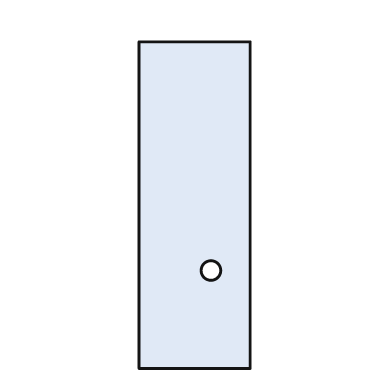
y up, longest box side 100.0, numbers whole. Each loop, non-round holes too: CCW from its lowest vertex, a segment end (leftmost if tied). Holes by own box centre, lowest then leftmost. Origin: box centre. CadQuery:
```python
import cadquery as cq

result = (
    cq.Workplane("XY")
    .moveTo(-17.0, -50.0)
    .lineTo(17.0, -50.0)
    .lineTo(17.0, 50.0)
    .lineTo(-17.0, 50.0)
    .close()
    .moveTo(5.0, -20.0)
    .circle(3.0)
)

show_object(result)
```